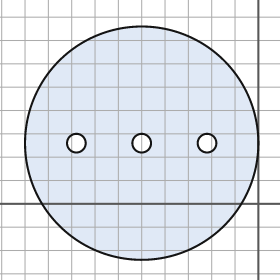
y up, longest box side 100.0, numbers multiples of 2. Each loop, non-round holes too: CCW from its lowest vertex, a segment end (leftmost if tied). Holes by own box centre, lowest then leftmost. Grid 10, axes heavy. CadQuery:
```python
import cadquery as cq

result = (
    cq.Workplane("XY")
    .moveTo(-50.0, 26.0)
    .circle(50.0)
    .moveTo(-78.0, 26.0)
    .circle(4.0)
    .moveTo(-50.0, 26.0)
    .circle(4.0)
    .moveTo(-22.0, 26.0)
    .circle(4.0)
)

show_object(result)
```